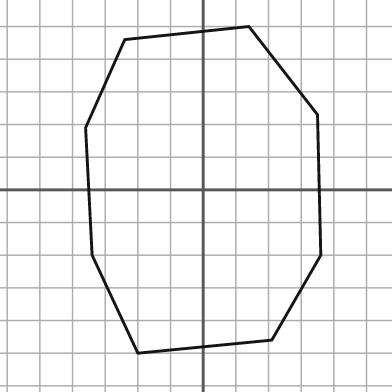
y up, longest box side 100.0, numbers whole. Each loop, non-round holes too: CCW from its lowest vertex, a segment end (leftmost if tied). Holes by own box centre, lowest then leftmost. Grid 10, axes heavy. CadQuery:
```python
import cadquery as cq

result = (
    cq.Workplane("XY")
    .moveTo(-20.0, -50.0)
    .lineTo(21.0, -46.0)
    .lineTo(36.0, -20.0)
    .lineTo(35.0, 23.0)
    .lineTo(14.0, 50.0)
    .lineTo(-24.0, 46.0)
    .lineTo(-36.0, 19.0)
    .lineTo(-34.0, -20.0)
    .close()
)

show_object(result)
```